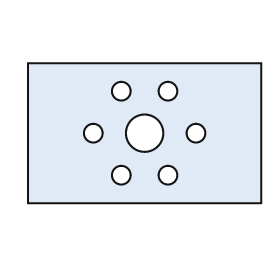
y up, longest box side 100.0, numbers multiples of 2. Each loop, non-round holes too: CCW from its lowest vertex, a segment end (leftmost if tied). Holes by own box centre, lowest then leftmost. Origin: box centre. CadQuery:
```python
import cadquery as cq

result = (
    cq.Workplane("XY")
    .moveTo(-50.0, -30.0)
    .lineTo(50.0, -30.0)
    .lineTo(50.0, 30.0)
    .lineTo(-50.0, 30.0)
    .close()
    .moveTo(-10.0, -18.0)
    .circle(4.0)
    .moveTo(10.0, -18.0)
    .circle(4.0)
    .moveTo(-22.0, 0.0)
    .circle(4.0)
    .moveTo(0.0, 0.0)
    .circle(8.0)
    .moveTo(22.0, 0.0)
    .circle(4.0)
    .moveTo(-10.0, 18.0)
    .circle(4.0)
    .moveTo(10.0, 18.0)
    .circle(4.0)
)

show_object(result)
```